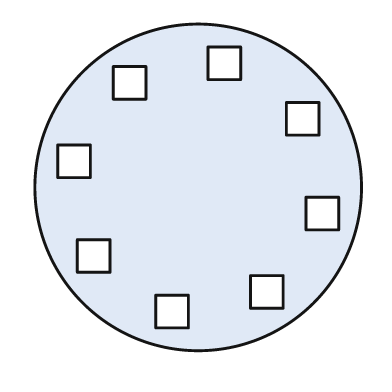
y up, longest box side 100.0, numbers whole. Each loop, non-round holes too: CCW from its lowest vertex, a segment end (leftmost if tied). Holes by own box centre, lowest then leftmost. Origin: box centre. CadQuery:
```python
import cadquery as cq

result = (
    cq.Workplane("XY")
    .moveTo(0.0, 0.0)
    .circle(50.0)
    .moveTo(-13.0, -43.0)
    .lineTo(-3.0, -43.0)
    .lineTo(-3.0, -33.0)
    .lineTo(-13.0, -33.0)
    .close()
    .moveTo(16.0, -37.0)
    .lineTo(26.0, -37.0)
    .lineTo(26.0, -27.0)
    .lineTo(16.0, -27.0)
    .close()
    .moveTo(-37.0, -26.0)
    .lineTo(-27.0, -26.0)
    .lineTo(-27.0, -16.0)
    .lineTo(-37.0, -16.0)
    .close()
    .moveTo(33.0, -13.0)
    .lineTo(43.0, -13.0)
    .lineTo(43.0, -3.0)
    .lineTo(33.0, -3.0)
    .close()
    .moveTo(-43.0, 3.0)
    .lineTo(-33.0, 3.0)
    .lineTo(-33.0, 13.0)
    .lineTo(-43.0, 13.0)
    .close()
    .moveTo(27.0, 16.0)
    .lineTo(37.0, 16.0)
    .lineTo(37.0, 26.0)
    .lineTo(27.0, 26.0)
    .close()
    .moveTo(-26.0, 27.0)
    .lineTo(-16.0, 27.0)
    .lineTo(-16.0, 37.0)
    .lineTo(-26.0, 37.0)
    .close()
    .moveTo(3.0, 33.0)
    .lineTo(13.0, 33.0)
    .lineTo(13.0, 43.0)
    .lineTo(3.0, 43.0)
    .close()
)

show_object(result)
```